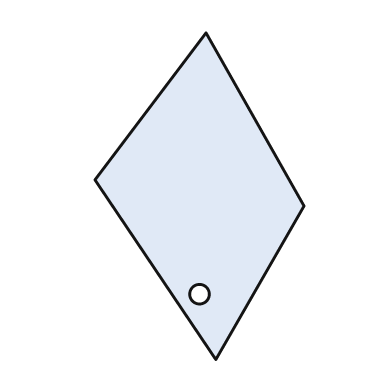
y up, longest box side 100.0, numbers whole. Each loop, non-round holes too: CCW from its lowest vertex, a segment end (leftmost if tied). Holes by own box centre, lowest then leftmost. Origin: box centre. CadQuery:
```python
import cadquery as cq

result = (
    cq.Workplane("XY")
    .moveTo(5.0, -50.0)
    .lineTo(32.0, -3.0)
    .lineTo(2.0, 50.0)
    .lineTo(-32.0, 5.0)
    .close()
    .moveTo(0.0, -30.0)
    .circle(3.0)
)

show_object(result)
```